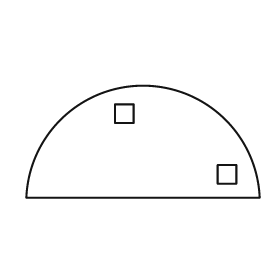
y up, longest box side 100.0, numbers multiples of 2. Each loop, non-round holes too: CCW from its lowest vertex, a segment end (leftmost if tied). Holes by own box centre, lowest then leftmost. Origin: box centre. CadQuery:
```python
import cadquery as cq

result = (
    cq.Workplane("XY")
    .moveTo(-50.0, -24.0)
    .lineTo(50.0, -24.0)
    .threePointArc((0.0, 24.0), (-50.0, -24.0))
    .close()
    .moveTo(32.0, -18.0)
    .lineTo(40.0, -18.0)
    .lineTo(40.0, -10.0)
    .lineTo(32.0, -10.0)
    .close()
    .moveTo(-12.0, 8.0)
    .lineTo(-4.0, 8.0)
    .lineTo(-4.0, 16.0)
    .lineTo(-12.0, 16.0)
    .close()
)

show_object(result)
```